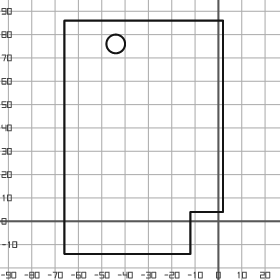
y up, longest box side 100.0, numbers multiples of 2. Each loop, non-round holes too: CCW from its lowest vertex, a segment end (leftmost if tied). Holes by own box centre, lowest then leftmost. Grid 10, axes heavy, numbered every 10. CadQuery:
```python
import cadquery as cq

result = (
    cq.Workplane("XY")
    .moveTo(-66.0, -14.0)
    .lineTo(-12.0, -14.0)
    .lineTo(-12.0, 4.0)
    .lineTo(2.0, 4.0)
    .lineTo(2.0, 86.0)
    .lineTo(-66.0, 86.0)
    .close()
    .moveTo(-44.0, 76.0)
    .circle(4.0)
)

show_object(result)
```